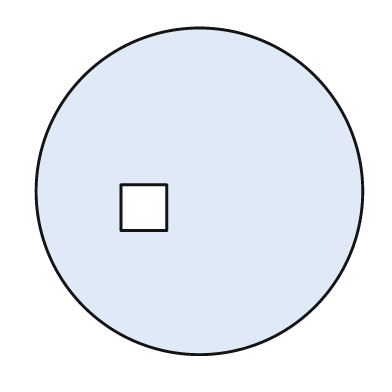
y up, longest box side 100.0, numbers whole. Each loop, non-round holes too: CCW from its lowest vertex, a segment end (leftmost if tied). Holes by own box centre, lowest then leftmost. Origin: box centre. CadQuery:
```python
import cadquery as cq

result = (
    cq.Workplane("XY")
    .moveTo(0.0, 0.0)
    .circle(50.0)
    .moveTo(-24.0, -12.0)
    .lineTo(-10.0, -12.0)
    .lineTo(-10.0, 2.0)
    .lineTo(-24.0, 2.0)
    .close()
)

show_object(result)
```